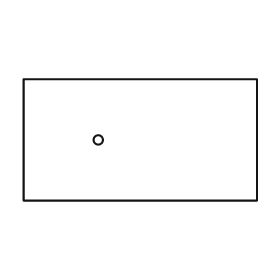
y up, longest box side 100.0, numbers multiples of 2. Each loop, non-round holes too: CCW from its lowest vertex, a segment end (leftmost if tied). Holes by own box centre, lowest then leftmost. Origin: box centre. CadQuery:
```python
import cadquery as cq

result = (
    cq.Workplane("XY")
    .moveTo(-50.0, -26.0)
    .lineTo(50.0, -26.0)
    .lineTo(50.0, 26.0)
    .lineTo(-50.0, 26.0)
    .close()
    .moveTo(-18.0, 0.0)
    .circle(2.0)
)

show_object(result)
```